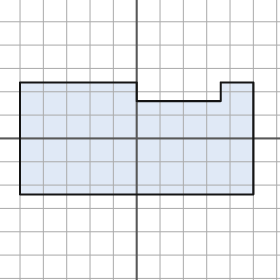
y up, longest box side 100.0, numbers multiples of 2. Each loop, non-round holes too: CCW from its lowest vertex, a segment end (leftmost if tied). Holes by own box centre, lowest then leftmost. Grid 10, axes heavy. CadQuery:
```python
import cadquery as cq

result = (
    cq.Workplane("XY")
    .moveTo(-50.0, -24.0)
    .lineTo(50.0, -24.0)
    .lineTo(50.0, 24.0)
    .lineTo(36.0, 24.0)
    .lineTo(36.0, 16.0)
    .lineTo(0.0, 16.0)
    .lineTo(0.0, 24.0)
    .lineTo(-50.0, 24.0)
    .close()
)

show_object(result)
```